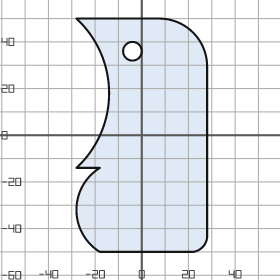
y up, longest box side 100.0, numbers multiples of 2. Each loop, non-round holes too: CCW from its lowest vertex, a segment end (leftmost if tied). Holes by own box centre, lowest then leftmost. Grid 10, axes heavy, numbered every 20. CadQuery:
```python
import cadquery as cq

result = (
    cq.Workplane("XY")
    .moveTo(-18.0, -50.0)
    .lineTo(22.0, -50.0)
    .threePointArc((26.0, -48.0), (28.0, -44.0))
    .lineTo(28.0, 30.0)
    .threePointArc((22.0, 44.0), (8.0, 50.0))
    .lineTo(-28.0, 50.0)
    .threePointArc((-14.0, 18.0), (-28.0, -14.0))
    .lineTo(-18.0, -14.0)
    .threePointArc((-28.0, -32.0), (-18.0, -50.0))
    .close()
    .moveTo(-4.0, 36.0)
    .circle(4.0)
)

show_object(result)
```